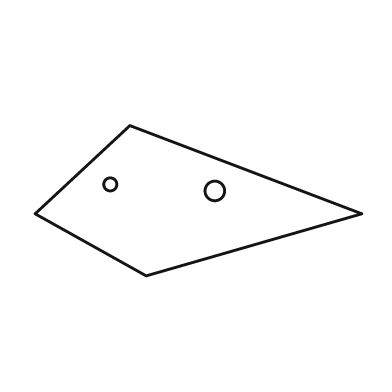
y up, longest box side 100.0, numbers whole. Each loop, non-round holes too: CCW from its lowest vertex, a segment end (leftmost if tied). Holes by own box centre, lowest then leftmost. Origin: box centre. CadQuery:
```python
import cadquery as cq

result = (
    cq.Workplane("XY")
    .moveTo(-16.0, -23.0)
    .lineTo(50.0, -4.0)
    .lineTo(-21.0, 23.0)
    .lineTo(-50.0, -4.0)
    .close()
    .moveTo(5.0, 3.0)
    .circle(3.0)
    .moveTo(-27.0, 5.0)
    .circle(2.0)
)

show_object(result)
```